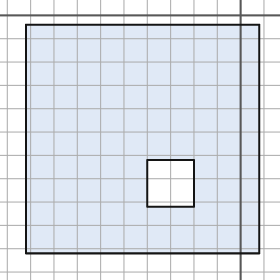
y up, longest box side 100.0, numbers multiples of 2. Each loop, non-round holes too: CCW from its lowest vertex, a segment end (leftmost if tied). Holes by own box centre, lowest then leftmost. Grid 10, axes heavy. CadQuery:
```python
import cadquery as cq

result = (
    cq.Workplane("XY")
    .moveTo(-92.0, -102.0)
    .lineTo(8.0, -102.0)
    .lineTo(8.0, -4.0)
    .lineTo(-92.0, -4.0)
    .close()
    .moveTo(-40.0, -82.0)
    .lineTo(-20.0, -82.0)
    .lineTo(-20.0, -62.0)
    .lineTo(-40.0, -62.0)
    .close()
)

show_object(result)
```